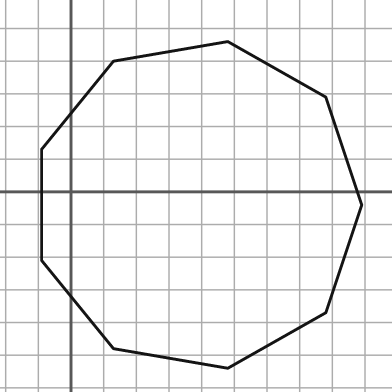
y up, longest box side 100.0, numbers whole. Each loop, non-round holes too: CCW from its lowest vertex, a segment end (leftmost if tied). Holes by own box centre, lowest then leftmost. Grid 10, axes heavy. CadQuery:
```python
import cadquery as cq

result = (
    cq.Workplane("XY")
    .moveTo(48.0, -54.0)
    .lineTo(78.0, -37.0)
    .lineTo(89.0, -4.0)
    .lineTo(78.0, 29.0)
    .lineTo(48.0, 46.0)
    .lineTo(13.0, 40.0)
    .lineTo(-9.0, 13.0)
    .lineTo(-9.0, -21.0)
    .lineTo(13.0, -48.0)
    .close()
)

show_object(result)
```